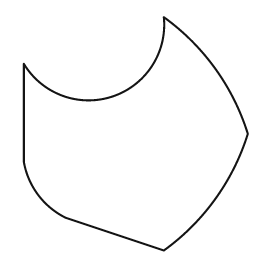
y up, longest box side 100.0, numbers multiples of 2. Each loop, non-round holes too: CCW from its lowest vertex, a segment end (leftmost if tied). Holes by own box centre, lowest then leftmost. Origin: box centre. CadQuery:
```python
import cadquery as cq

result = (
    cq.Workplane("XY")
    .moveTo(12.0, -50.0)
    .threePointArc((34.0, -28.0), (48.0, 0.0))
    .threePointArc((34.0, 28.0), (12.0, 50.0))
    .threePointArc((-10.0, 16.0), (-48.0, 30.0))
    .lineTo(-48.0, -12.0)
    .threePointArc((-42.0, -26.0), (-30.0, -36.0))
    .close()
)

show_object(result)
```